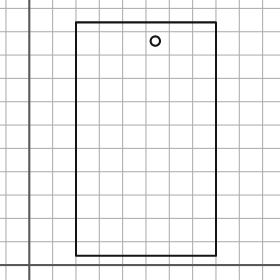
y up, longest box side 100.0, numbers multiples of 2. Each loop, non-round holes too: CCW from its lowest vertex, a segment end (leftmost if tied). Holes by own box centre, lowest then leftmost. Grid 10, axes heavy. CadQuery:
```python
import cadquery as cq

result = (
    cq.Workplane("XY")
    .moveTo(20.0, 4.0)
    .lineTo(80.0, 4.0)
    .lineTo(80.0, 104.0)
    .lineTo(20.0, 104.0)
    .close()
    .moveTo(54.0, 96.0)
    .circle(2.0)
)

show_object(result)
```